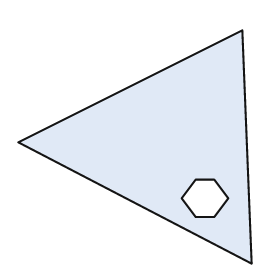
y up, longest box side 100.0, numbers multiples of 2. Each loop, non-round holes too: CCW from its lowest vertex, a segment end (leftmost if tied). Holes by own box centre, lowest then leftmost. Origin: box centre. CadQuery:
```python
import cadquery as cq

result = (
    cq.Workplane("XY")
    .moveTo(50.0, -50.0)
    .lineTo(46.0, 50.0)
    .lineTo(-50.0, 2.0)
    .close()
    .moveTo(26.0, -30.0)
    .lineTo(34.0, -30.0)
    .lineTo(40.0, -22.0)
    .lineTo(34.0, -14.0)
    .lineTo(26.0, -14.0)
    .lineTo(20.0, -22.0)
    .close()
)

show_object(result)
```